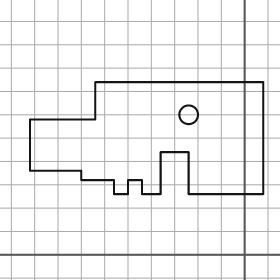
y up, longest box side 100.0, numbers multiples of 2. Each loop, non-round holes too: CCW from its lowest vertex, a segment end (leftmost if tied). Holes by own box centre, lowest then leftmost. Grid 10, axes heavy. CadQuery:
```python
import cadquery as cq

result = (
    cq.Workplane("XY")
    .moveTo(-56.0, 26.0)
    .lineTo(-50.0, 26.0)
    .lineTo(-50.0, 32.0)
    .lineTo(-44.0, 32.0)
    .lineTo(-44.0, 26.0)
    .lineTo(-36.0, 26.0)
    .lineTo(-36.0, 44.0)
    .lineTo(-24.0, 44.0)
    .lineTo(-24.0, 26.0)
    .lineTo(8.0, 26.0)
    .lineTo(8.0, 74.0)
    .lineTo(-64.0, 74.0)
    .lineTo(-64.0, 58.0)
    .lineTo(-92.0, 58.0)
    .lineTo(-92.0, 36.0)
    .lineTo(-70.0, 36.0)
    .lineTo(-70.0, 32.0)
    .lineTo(-56.0, 32.0)
    .close()
    .moveTo(-24.0, 60.0)
    .circle(4.0)
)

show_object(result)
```